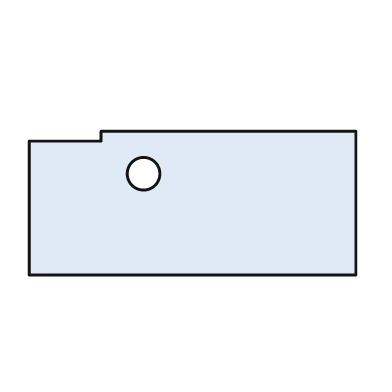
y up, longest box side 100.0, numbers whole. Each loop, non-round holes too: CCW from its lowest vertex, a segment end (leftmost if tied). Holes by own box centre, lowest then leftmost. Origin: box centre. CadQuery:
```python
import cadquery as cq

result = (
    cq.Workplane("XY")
    .moveTo(-50.0, -22.0)
    .lineTo(50.0, -22.0)
    .lineTo(50.0, 22.0)
    .lineTo(-28.0, 22.0)
    .lineTo(-28.0, 19.0)
    .lineTo(-50.0, 19.0)
    .close()
    .moveTo(-15.0, 9.0)
    .circle(5.0)
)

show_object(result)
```